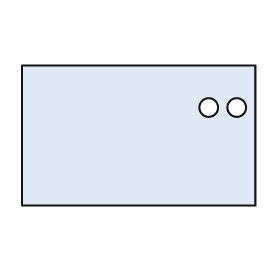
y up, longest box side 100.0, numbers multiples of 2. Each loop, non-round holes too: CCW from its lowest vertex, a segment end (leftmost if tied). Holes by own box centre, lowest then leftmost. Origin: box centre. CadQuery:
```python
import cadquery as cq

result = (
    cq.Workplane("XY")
    .moveTo(-50.0, -30.0)
    .lineTo(50.0, -30.0)
    .lineTo(50.0, 30.0)
    .lineTo(-50.0, 30.0)
    .close()
    .moveTo(30.0, 12.0)
    .circle(4.0)
    .moveTo(42.0, 12.0)
    .circle(4.0)
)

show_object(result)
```